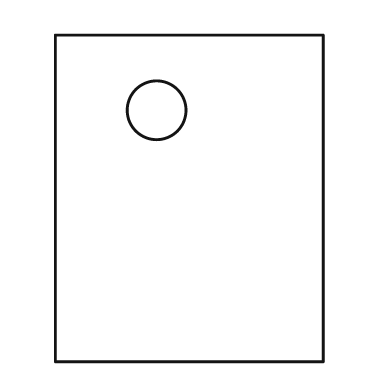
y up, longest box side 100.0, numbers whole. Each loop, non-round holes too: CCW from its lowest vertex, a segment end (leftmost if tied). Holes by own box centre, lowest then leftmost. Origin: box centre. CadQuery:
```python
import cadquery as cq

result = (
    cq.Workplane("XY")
    .moveTo(-41.0, -50.0)
    .lineTo(41.0, -50.0)
    .lineTo(41.0, 50.0)
    .lineTo(-41.0, 50.0)
    .close()
    .moveTo(-10.0, 27.0)
    .circle(9.0)
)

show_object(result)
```